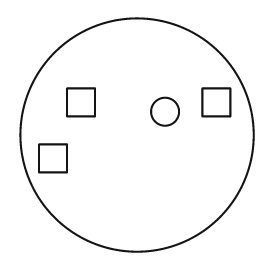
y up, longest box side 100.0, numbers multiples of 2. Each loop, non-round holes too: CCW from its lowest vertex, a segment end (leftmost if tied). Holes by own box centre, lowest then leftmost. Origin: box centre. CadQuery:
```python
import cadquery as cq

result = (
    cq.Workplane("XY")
    .moveTo(0.0, 0.0)
    .circle(50.0)
    .moveTo(-42.0, -16.0)
    .lineTo(-30.0, -16.0)
    .lineTo(-30.0, -4.0)
    .lineTo(-42.0, -4.0)
    .close()
    .moveTo(12.0, 10.0)
    .circle(6.0)
    .moveTo(-30.0, 8.0)
    .lineTo(-18.0, 8.0)
    .lineTo(-18.0, 20.0)
    .lineTo(-30.0, 20.0)
    .close()
    .moveTo(28.0, 8.0)
    .lineTo(40.0, 8.0)
    .lineTo(40.0, 20.0)
    .lineTo(28.0, 20.0)
    .close()
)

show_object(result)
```